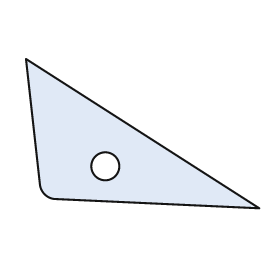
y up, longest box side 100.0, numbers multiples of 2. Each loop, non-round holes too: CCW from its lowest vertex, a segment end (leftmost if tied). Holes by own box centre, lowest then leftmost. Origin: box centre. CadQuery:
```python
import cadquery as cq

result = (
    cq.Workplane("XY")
    .moveTo(50.0, -32.0)
    .lineTo(-50.0, 32.0)
    .lineTo(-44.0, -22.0)
    .threePointArc((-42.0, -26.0), (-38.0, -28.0))
    .close()
    .moveTo(-16.0, -14.0)
    .circle(6.0)
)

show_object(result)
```